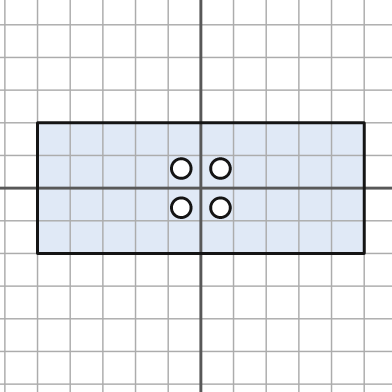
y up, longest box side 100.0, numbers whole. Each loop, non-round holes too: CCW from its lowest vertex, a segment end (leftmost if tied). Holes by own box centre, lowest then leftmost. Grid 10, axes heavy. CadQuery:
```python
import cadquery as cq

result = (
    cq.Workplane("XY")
    .moveTo(-50.0, -20.0)
    .lineTo(50.0, -20.0)
    .lineTo(50.0, 20.0)
    .lineTo(-50.0, 20.0)
    .close()
    .moveTo(-6.0, -6.0)
    .circle(3.0)
    .moveTo(6.0, -6.0)
    .circle(3.0)
    .moveTo(-6.0, 6.0)
    .circle(3.0)
    .moveTo(6.0, 6.0)
    .circle(3.0)
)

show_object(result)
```